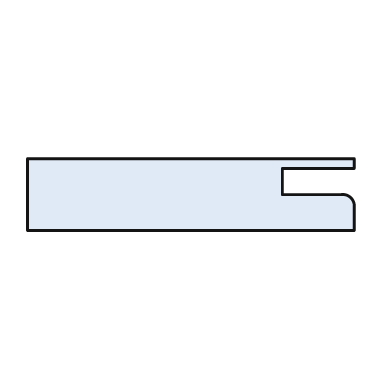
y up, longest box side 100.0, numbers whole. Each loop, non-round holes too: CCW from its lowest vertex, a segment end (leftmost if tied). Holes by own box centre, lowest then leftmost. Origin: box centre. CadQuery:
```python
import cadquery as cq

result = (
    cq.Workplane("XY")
    .moveTo(-50.0, -11.0)
    .lineTo(50.0, -11.0)
    .lineTo(50.0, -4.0)
    .threePointArc((49.0, -1.0), (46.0, 0.0))
    .lineTo(28.0, 0.0)
    .lineTo(28.0, 8.0)
    .lineTo(50.0, 8.0)
    .lineTo(50.0, 11.0)
    .lineTo(-50.0, 11.0)
    .close()
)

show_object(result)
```